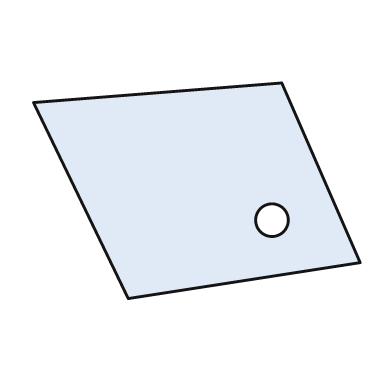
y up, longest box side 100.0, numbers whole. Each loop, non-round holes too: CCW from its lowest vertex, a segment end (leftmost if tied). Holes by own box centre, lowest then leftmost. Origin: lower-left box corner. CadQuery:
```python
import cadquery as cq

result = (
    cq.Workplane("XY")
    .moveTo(29.0, 0.0)
    .lineTo(100.0, 11.0)
    .lineTo(76.0, 66.0)
    .lineTo(0.0, 60.0)
    .close()
    .moveTo(73.0, 24.0)
    .circle(5.0)
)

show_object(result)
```